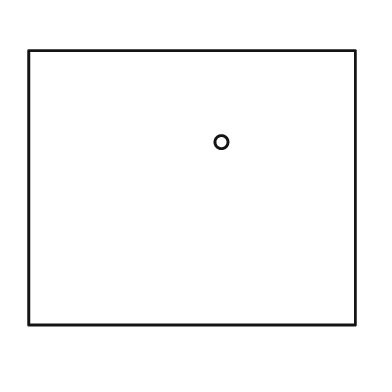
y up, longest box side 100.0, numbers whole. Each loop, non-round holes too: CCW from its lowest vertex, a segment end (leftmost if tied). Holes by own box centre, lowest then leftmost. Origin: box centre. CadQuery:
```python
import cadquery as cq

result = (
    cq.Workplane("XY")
    .moveTo(-50.0, -42.0)
    .lineTo(50.0, -42.0)
    .lineTo(50.0, 42.0)
    .lineTo(-50.0, 42.0)
    .close()
    .moveTo(9.0, 14.0)
    .circle(2.0)
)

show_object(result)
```